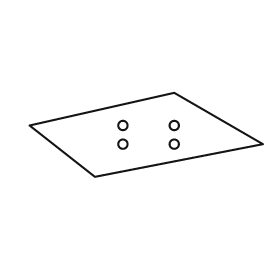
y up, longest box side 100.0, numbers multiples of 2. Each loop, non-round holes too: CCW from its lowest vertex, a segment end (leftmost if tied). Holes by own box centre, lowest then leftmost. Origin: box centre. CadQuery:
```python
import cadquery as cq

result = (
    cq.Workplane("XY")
    .moveTo(-22.0, -18.0)
    .lineTo(50.0, -4.0)
    .lineTo(12.0, 18.0)
    .lineTo(-50.0, 4.0)
    .close()
    .moveTo(-10.0, -4.0)
    .circle(2.0)
    .moveTo(12.0, -4.0)
    .circle(2.0)
    .moveTo(-10.0, 4.0)
    .circle(2.0)
    .moveTo(12.0, 4.0)
    .circle(2.0)
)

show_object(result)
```